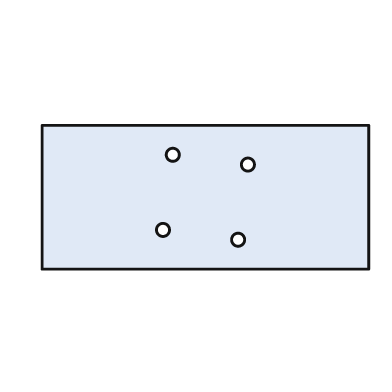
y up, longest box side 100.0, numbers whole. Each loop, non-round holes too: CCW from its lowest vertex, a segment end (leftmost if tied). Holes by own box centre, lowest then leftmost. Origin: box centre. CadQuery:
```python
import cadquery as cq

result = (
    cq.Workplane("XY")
    .moveTo(-50.0, -22.0)
    .lineTo(50.0, -22.0)
    .lineTo(50.0, 22.0)
    .lineTo(-50.0, 22.0)
    .close()
    .moveTo(10.0, -13.0)
    .circle(2.0)
    .moveTo(-13.0, -10.0)
    .circle(2.0)
    .moveTo(13.0, 10.0)
    .circle(2.0)
    .moveTo(-10.0, 13.0)
    .circle(2.0)
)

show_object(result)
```